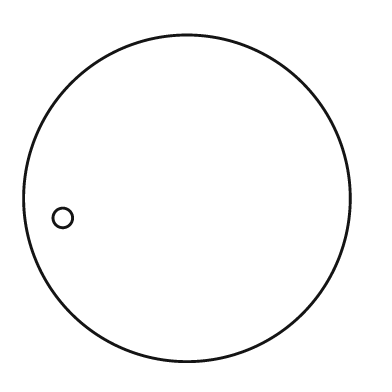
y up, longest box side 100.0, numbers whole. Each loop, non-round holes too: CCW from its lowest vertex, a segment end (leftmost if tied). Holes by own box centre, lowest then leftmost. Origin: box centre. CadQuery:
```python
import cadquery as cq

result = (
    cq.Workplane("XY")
    .moveTo(0.0, 0.0)
    .circle(50.0)
    .moveTo(-38.0, -6.0)
    .circle(3.0)
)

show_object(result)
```